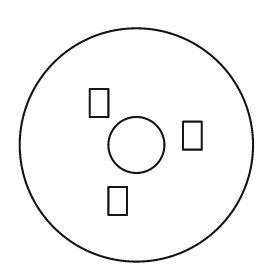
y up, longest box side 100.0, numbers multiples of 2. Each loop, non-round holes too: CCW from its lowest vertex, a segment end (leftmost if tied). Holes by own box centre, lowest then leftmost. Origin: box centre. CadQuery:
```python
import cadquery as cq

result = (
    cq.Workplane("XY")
    .moveTo(0.0, 0.0)
    .circle(50.0)
    .moveTo(-12.0, -30.0)
    .lineTo(-4.0, -30.0)
    .lineTo(-4.0, -18.0)
    .lineTo(-12.0, -18.0)
    .close()
    .moveTo(0.0, 0.0)
    .circle(12.0)
    .moveTo(20.0, -2.0)
    .lineTo(28.0, -2.0)
    .lineTo(28.0, 10.0)
    .lineTo(20.0, 10.0)
    .close()
    .moveTo(-20.0, 12.0)
    .lineTo(-12.0, 12.0)
    .lineTo(-12.0, 24.0)
    .lineTo(-20.0, 24.0)
    .close()
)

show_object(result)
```